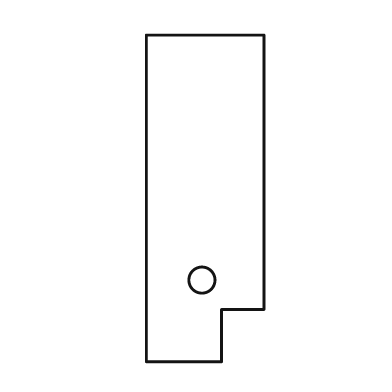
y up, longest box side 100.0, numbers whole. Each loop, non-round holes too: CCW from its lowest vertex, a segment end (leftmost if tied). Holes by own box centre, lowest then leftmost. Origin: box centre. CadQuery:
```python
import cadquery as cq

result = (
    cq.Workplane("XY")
    .moveTo(-18.0, -50.0)
    .lineTo(5.0, -50.0)
    .lineTo(5.0, -34.0)
    .lineTo(18.0, -34.0)
    .lineTo(18.0, 50.0)
    .lineTo(-18.0, 50.0)
    .close()
    .moveTo(-1.0, -25.0)
    .circle(4.0)
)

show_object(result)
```